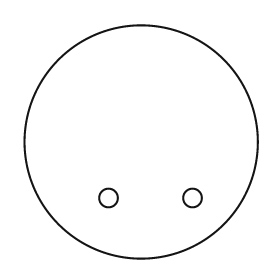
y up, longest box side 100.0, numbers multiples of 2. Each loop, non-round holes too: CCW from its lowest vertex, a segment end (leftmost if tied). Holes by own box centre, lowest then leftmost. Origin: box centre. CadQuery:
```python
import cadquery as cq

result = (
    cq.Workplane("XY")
    .moveTo(0.0, 0.0)
    .circle(50.0)
    .moveTo(-14.0, -24.0)
    .circle(4.0)
    .moveTo(22.0, -24.0)
    .circle(4.0)
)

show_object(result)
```